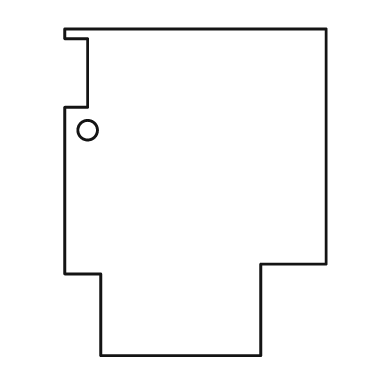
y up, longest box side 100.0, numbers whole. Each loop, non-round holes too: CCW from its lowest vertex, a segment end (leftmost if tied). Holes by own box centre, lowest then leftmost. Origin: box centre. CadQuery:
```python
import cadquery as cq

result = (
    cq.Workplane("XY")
    .moveTo(-29.0, -50.0)
    .lineTo(20.0, -50.0)
    .lineTo(20.0, -22.0)
    .lineTo(40.0, -22.0)
    .lineTo(40.0, 50.0)
    .lineTo(-40.0, 50.0)
    .lineTo(-40.0, 47.0)
    .lineTo(-33.0, 47.0)
    .lineTo(-33.0, 26.0)
    .lineTo(-40.0, 26.0)
    .lineTo(-40.0, -25.0)
    .lineTo(-29.0, -25.0)
    .close()
    .moveTo(-33.0, 19.0)
    .circle(3.0)
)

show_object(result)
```